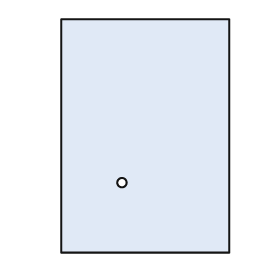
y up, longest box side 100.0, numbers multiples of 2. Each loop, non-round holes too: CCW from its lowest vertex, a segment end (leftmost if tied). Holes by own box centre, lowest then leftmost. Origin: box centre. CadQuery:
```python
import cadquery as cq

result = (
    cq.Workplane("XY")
    .moveTo(-36.0, -50.0)
    .lineTo(36.0, -50.0)
    .lineTo(36.0, 50.0)
    .lineTo(-36.0, 50.0)
    .close()
    .moveTo(-10.0, -20.0)
    .circle(2.0)
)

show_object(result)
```